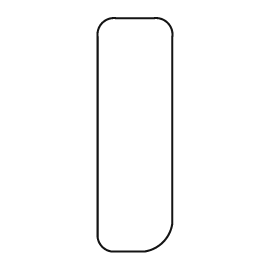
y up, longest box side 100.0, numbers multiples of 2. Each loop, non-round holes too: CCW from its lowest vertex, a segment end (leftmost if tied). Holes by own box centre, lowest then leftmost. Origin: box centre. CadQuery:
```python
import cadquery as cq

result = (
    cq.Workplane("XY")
    .moveTo(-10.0, -50.0)
    .lineTo(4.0, -50.0)
    .threePointArc((12.0, -46.0), (16.0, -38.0))
    .lineTo(16.0, 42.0)
    .threePointArc((14.0, 48.0), (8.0, 50.0))
    .lineTo(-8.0, 50.0)
    .threePointArc((-14.0, 48.0), (-16.0, 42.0))
    .lineTo(-16.0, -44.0)
    .threePointArc((-14.0, -48.0), (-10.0, -50.0))
    .close()
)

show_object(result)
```